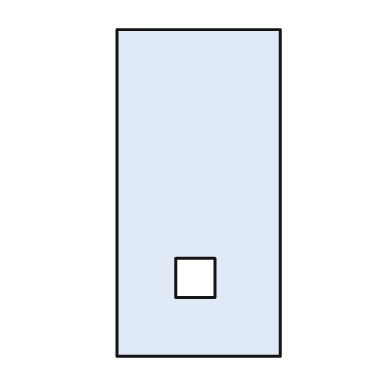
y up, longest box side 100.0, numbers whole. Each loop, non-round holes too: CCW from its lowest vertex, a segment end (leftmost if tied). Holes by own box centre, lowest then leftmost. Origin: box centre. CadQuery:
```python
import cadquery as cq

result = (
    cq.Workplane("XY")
    .moveTo(-25.0, -50.0)
    .lineTo(25.0, -50.0)
    .lineTo(25.0, 50.0)
    .lineTo(-25.0, 50.0)
    .close()
    .moveTo(-7.0, -32.0)
    .lineTo(5.0, -32.0)
    .lineTo(5.0, -20.0)
    .lineTo(-7.0, -20.0)
    .close()
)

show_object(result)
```